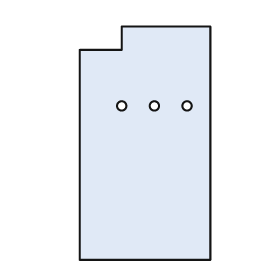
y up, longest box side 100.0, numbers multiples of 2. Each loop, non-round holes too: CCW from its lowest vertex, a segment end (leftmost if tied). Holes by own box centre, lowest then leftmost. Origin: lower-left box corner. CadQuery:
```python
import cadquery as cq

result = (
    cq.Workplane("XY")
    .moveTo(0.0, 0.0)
    .lineTo(56.0, 0.0)
    .lineTo(56.0, 100.0)
    .lineTo(18.0, 100.0)
    .lineTo(18.0, 90.0)
    .lineTo(0.0, 90.0)
    .close()
    .moveTo(18.0, 66.0)
    .circle(2.0)
    .moveTo(32.0, 66.0)
    .circle(2.0)
    .moveTo(46.0, 66.0)
    .circle(2.0)
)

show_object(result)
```